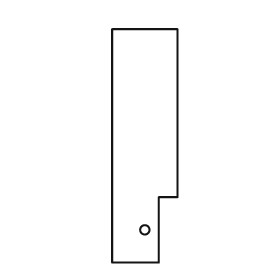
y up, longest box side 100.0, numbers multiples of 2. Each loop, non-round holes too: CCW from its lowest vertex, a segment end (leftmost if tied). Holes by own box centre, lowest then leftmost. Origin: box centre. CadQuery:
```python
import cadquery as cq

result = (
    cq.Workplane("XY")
    .moveTo(-14.0, -50.0)
    .lineTo(6.0, -50.0)
    .lineTo(6.0, -22.0)
    .lineTo(14.0, -22.0)
    .lineTo(14.0, 50.0)
    .lineTo(-14.0, 50.0)
    .close()
    .moveTo(0.0, -36.0)
    .circle(2.0)
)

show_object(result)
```